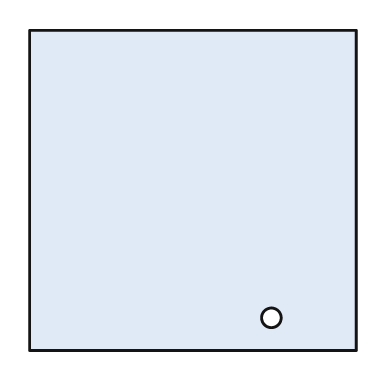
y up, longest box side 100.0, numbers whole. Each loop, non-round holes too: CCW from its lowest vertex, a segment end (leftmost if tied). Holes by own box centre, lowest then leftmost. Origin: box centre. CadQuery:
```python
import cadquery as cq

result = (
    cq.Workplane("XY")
    .moveTo(-50.0, -49.0)
    .lineTo(50.0, -49.0)
    .lineTo(50.0, 49.0)
    .lineTo(-50.0, 49.0)
    .close()
    .moveTo(24.0, -39.0)
    .circle(3.0)
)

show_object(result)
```